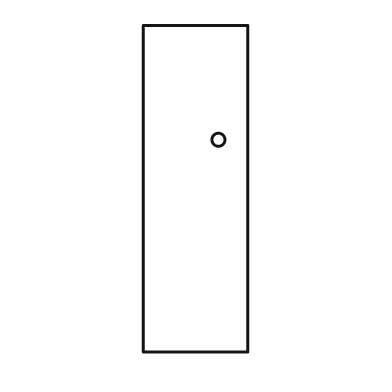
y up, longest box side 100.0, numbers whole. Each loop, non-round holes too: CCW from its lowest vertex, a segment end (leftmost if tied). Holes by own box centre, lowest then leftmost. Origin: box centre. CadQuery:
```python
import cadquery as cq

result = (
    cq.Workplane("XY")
    .moveTo(-16.0, -50.0)
    .lineTo(16.0, -50.0)
    .lineTo(16.0, 50.0)
    .lineTo(-16.0, 50.0)
    .close()
    .moveTo(7.0, 15.0)
    .circle(2.0)
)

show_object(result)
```